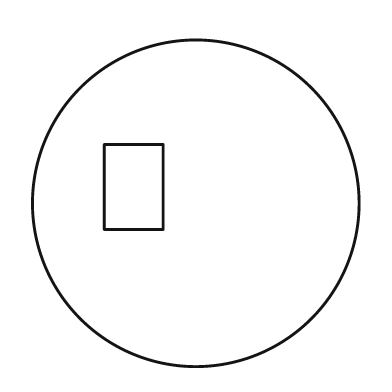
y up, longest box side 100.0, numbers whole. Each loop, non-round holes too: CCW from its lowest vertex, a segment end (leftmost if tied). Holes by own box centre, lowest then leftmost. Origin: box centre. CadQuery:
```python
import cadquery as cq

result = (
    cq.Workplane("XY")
    .moveTo(0.0, 0.0)
    .circle(50.0)
    .moveTo(-28.0, -8.0)
    .lineTo(-10.0, -8.0)
    .lineTo(-10.0, 18.0)
    .lineTo(-28.0, 18.0)
    .close()
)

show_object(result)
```